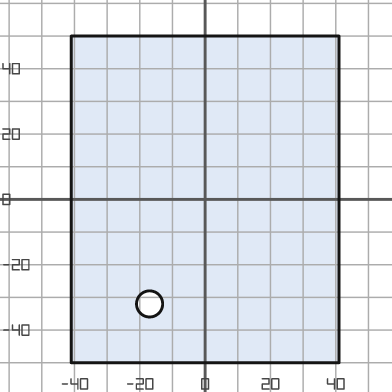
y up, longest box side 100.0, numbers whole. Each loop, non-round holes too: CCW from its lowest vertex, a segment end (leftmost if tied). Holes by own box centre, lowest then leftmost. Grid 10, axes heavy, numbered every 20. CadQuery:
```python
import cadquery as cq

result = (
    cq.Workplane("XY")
    .moveTo(-41.0, -50.0)
    .lineTo(41.0, -50.0)
    .lineTo(41.0, 50.0)
    .lineTo(-41.0, 50.0)
    .close()
    .moveTo(-17.0, -32.0)
    .circle(4.0)
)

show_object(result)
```